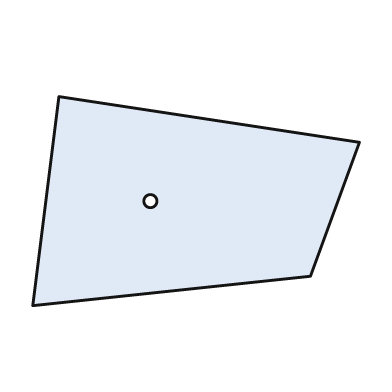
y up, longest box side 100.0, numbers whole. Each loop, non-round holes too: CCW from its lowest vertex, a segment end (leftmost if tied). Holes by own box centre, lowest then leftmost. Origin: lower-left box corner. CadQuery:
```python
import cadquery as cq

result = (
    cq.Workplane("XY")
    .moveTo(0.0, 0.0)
    .lineTo(85.0, 9.0)
    .lineTo(100.0, 50.0)
    .lineTo(8.0, 64.0)
    .close()
    .moveTo(36.0, 32.0)
    .circle(2.0)
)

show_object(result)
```